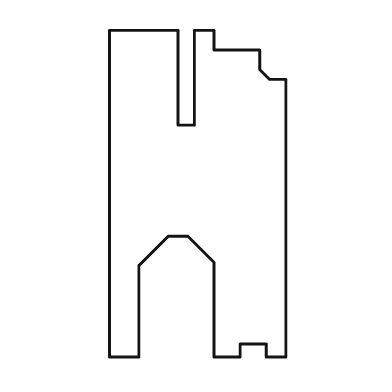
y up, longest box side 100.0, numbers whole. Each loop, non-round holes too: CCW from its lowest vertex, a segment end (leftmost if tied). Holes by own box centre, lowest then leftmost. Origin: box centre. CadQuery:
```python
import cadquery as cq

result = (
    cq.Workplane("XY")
    .moveTo(-27.0, -50.0)
    .lineTo(-18.0, -50.0)
    .lineTo(-18.0, -22.0)
    .lineTo(-9.0, -13.0)
    .lineTo(-3.0, -13.0)
    .lineTo(5.0, -21.0)
    .lineTo(5.0, -50.0)
    .lineTo(13.0, -50.0)
    .lineTo(13.0, -46.0)
    .lineTo(21.0, -46.0)
    .lineTo(21.0, -50.0)
    .lineTo(27.0, -50.0)
    .lineTo(27.0, 35.0)
    .lineTo(22.0, 35.0)
    .lineTo(19.0, 38.0)
    .lineTo(19.0, 44.0)
    .lineTo(5.0, 44.0)
    .lineTo(5.0, 50.0)
    .lineTo(-1.0, 50.0)
    .lineTo(-1.0, 21.0)
    .lineTo(-6.0, 21.0)
    .lineTo(-6.0, 50.0)
    .lineTo(-27.0, 50.0)
    .close()
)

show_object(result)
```